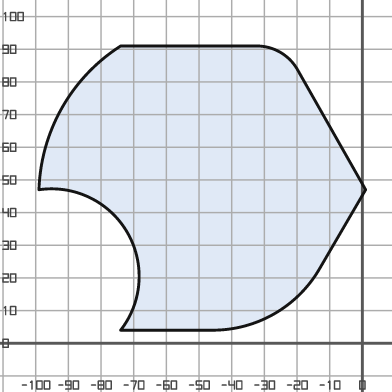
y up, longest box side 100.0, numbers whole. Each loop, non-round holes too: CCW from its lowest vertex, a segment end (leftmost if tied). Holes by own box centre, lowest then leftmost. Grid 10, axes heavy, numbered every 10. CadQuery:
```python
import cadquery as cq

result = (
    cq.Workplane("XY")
    .moveTo(-74.0, 4.0)
    .lineTo(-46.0, 4.0)
    .threePointArc((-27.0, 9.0), (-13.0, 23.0))
    .lineTo(1.0, 47.0)
    .lineTo(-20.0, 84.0)
    .threePointArc((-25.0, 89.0), (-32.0, 91.0))
    .lineTo(-74.0, 91.0)
    .threePointArc((-92.0, 72.0), (-99.0, 47.0))
    .threePointArc((-72.0, 34.0), (-74.0, 4.0))
    .close()
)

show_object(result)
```